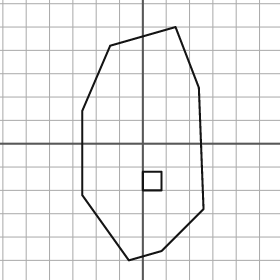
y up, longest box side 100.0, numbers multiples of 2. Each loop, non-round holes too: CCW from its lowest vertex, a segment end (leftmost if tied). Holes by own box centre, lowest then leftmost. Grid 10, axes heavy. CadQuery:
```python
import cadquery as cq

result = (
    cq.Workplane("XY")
    .moveTo(-6.0, -50.0)
    .lineTo(8.0, -46.0)
    .lineTo(26.0, -28.0)
    .lineTo(24.0, 24.0)
    .lineTo(14.0, 50.0)
    .lineTo(-14.0, 42.0)
    .lineTo(-26.0, 14.0)
    .lineTo(-26.0, -22.0)
    .close()
    .moveTo(0.0, -20.0)
    .lineTo(8.0, -20.0)
    .lineTo(8.0, -12.0)
    .lineTo(0.0, -12.0)
    .close()
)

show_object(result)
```